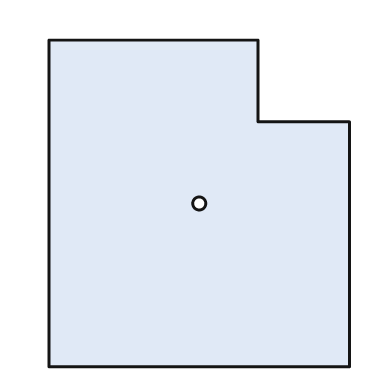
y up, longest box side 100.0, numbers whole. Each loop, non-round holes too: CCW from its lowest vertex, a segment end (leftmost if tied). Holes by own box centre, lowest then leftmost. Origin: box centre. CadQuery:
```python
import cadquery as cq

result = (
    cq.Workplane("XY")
    .moveTo(-46.0, -50.0)
    .lineTo(46.0, -50.0)
    .lineTo(46.0, 25.0)
    .lineTo(18.0, 25.0)
    .lineTo(18.0, 50.0)
    .lineTo(-46.0, 50.0)
    .close()
    .moveTo(0.0, 0.0)
    .circle(2.0)
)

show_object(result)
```